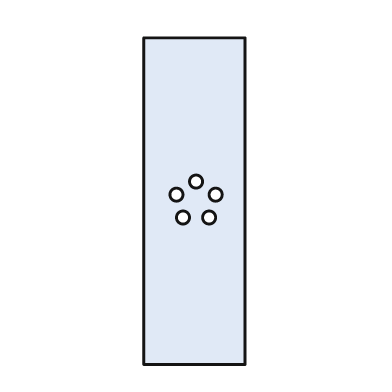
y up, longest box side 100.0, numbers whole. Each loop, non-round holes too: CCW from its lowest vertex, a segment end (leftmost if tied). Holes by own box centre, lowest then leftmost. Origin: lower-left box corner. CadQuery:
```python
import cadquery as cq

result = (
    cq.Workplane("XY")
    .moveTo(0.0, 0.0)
    .lineTo(31.0, 0.0)
    .lineTo(31.0, 100.0)
    .lineTo(0.0, 100.0)
    .close()
    .moveTo(12.0, 45.0)
    .circle(2.0)
    .moveTo(20.0, 45.0)
    .circle(2.0)
    .moveTo(10.0, 52.0)
    .circle(2.0)
    .moveTo(22.0, 52.0)
    .circle(2.0)
    .moveTo(16.0, 56.0)
    .circle(2.0)
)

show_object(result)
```